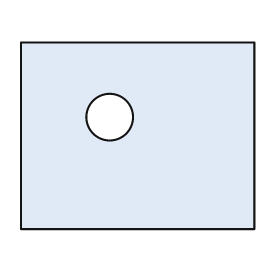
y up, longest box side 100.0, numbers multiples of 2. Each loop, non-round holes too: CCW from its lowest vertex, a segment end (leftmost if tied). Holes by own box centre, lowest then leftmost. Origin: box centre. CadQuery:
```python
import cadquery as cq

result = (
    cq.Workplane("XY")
    .moveTo(-50.0, -40.0)
    .lineTo(50.0, -40.0)
    .lineTo(50.0, 40.0)
    .lineTo(-50.0, 40.0)
    .close()
    .moveTo(-12.0, 8.0)
    .circle(10.0)
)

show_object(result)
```